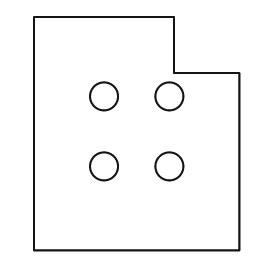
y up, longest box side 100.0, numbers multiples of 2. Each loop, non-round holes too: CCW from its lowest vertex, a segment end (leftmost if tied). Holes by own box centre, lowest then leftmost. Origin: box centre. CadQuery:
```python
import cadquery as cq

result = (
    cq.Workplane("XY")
    .moveTo(-44.0, -50.0)
    .lineTo(44.0, -50.0)
    .lineTo(44.0, 26.0)
    .lineTo(16.0, 26.0)
    .lineTo(16.0, 50.0)
    .lineTo(-44.0, 50.0)
    .close()
    .moveTo(-14.0, -14.0)
    .circle(6.0)
    .moveTo(14.0, -14.0)
    .circle(6.0)
    .moveTo(-14.0, 16.0)
    .circle(6.0)
    .moveTo(14.0, 16.0)
    .circle(6.0)
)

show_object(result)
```